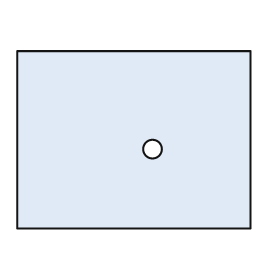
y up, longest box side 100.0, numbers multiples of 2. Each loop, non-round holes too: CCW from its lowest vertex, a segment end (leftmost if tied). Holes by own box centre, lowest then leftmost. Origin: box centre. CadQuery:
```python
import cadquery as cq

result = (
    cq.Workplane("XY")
    .moveTo(-50.0, -38.0)
    .lineTo(50.0, -38.0)
    .lineTo(50.0, 38.0)
    .lineTo(-50.0, 38.0)
    .close()
    .moveTo(8.0, -4.0)
    .circle(4.0)
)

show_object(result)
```